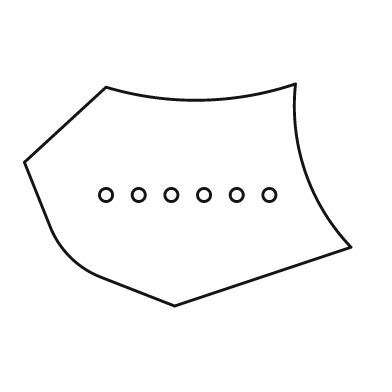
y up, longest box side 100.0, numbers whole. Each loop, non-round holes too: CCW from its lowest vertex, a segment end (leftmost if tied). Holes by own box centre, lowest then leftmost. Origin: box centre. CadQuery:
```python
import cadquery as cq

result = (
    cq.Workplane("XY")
    .moveTo(-4.0, -34.0)
    .lineTo(50.0, -16.0)
    .threePointArc((36.0, 7.0), (33.0, 34.0))
    .threePointArc((4.0, 29.0), (-25.0, 33.0))
    .lineTo(-50.0, 10.0)
    .lineTo(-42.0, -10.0)
    .threePointArc((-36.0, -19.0), (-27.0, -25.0))
    .close()
    .moveTo(-25.0, 0.0)
    .circle(2.0)
    .moveTo(-15.0, 0.0)
    .circle(2.0)
    .moveTo(-5.0, 0.0)
    .circle(2.0)
    .moveTo(5.0, 0.0)
    .circle(2.0)
    .moveTo(15.0, 0.0)
    .circle(2.0)
    .moveTo(25.0, 0.0)
    .circle(2.0)
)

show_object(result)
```